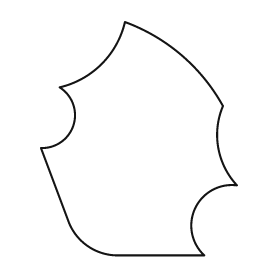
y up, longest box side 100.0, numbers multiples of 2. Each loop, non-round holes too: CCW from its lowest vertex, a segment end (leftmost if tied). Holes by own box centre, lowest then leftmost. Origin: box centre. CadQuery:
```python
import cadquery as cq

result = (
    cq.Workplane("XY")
    .moveTo(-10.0, -50.0)
    .lineTo(28.0, -50.0)
    .threePointArc((24.0, -30.0), (42.0, -20.0))
    .threePointArc((34.0, -4.0), (36.0, 14.0))
    .threePointArc((18.0, 36.0), (-6.0, 50.0))
    .threePointArc((-16.0, 32.0), (-34.0, 22.0))
    .threePointArc((-28.0, 6.0), (-42.0, -4.0))
    .lineTo(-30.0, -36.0)
    .threePointArc((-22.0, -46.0), (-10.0, -50.0))
    .close()
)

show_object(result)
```